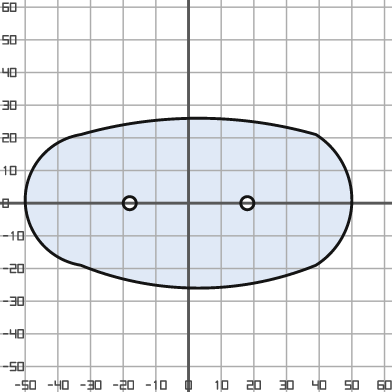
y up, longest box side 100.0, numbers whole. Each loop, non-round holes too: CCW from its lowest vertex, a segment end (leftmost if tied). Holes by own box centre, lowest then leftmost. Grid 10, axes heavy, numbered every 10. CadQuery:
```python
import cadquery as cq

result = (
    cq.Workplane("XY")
    .moveTo(-33.0, -19.0)
    .threePointArc((3.0, -26.0), (39.0, -19.0))
    .threePointArc((50.0, 1.0), (39.0, 21.0))
    .threePointArc((3.0, 26.0), (-33.0, 21.0))
    .threePointArc((-50.0, 1.0), (-33.0, -19.0))
    .close()
    .moveTo(-18.0, 0.0)
    .circle(2.0)
    .moveTo(18.0, 0.0)
    .circle(2.0)
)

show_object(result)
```